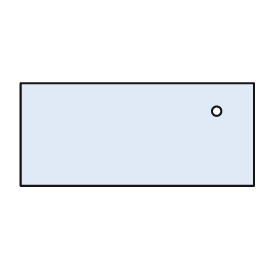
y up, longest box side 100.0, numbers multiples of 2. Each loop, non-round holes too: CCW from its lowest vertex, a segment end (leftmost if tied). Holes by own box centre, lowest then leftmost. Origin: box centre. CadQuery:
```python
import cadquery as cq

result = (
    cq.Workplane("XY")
    .moveTo(-50.0, -22.0)
    .lineTo(50.0, -22.0)
    .lineTo(50.0, 22.0)
    .lineTo(-50.0, 22.0)
    .close()
    .moveTo(34.0, 10.0)
    .circle(2.0)
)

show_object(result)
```